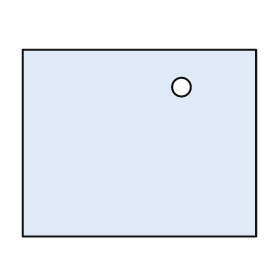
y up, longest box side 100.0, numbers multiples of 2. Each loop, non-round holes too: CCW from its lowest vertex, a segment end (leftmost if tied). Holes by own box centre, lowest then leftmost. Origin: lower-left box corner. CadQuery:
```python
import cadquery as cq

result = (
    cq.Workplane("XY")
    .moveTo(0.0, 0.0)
    .lineTo(100.0, 0.0)
    .lineTo(100.0, 80.0)
    .lineTo(0.0, 80.0)
    .close()
    .moveTo(68.0, 64.0)
    .circle(4.0)
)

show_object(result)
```